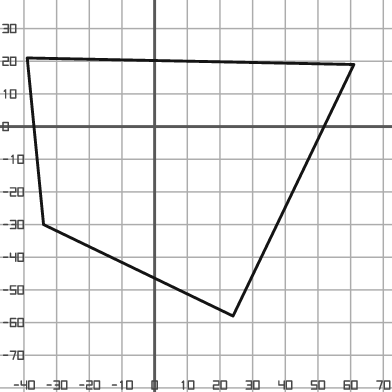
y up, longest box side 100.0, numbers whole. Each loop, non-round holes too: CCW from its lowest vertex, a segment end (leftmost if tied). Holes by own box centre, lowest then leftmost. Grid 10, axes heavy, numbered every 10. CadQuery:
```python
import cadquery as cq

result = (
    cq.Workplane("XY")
    .moveTo(24.0, -58.0)
    .lineTo(61.0, 19.0)
    .lineTo(-39.0, 21.0)
    .lineTo(-34.0, -30.0)
    .close()
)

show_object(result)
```